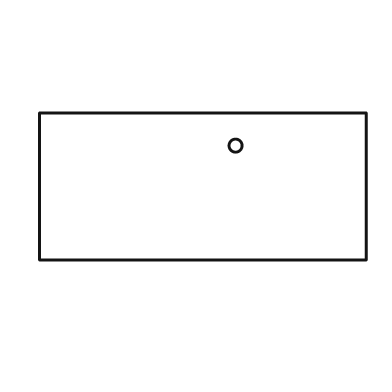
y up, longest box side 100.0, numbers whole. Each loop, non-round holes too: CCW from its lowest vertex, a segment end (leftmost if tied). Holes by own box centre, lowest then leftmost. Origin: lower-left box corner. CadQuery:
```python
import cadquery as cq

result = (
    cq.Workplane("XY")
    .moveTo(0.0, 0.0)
    .lineTo(100.0, 0.0)
    .lineTo(100.0, 45.0)
    .lineTo(0.0, 45.0)
    .close()
    .moveTo(60.0, 35.0)
    .circle(2.0)
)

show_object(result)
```